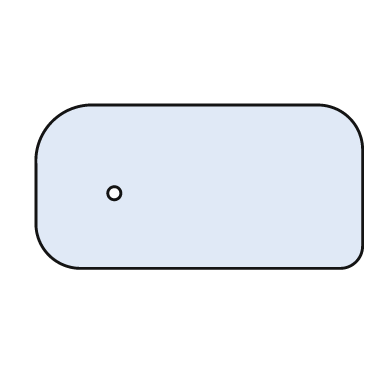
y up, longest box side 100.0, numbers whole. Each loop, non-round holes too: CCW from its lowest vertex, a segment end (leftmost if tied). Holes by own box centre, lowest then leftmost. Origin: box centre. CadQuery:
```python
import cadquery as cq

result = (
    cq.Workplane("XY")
    .moveTo(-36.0, -25.0)
    .lineTo(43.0, -25.0)
    .threePointArc((48.0, -23.0), (50.0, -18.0))
    .lineTo(50.0, 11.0)
    .threePointArc((46.0, 21.0), (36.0, 25.0))
    .lineTo(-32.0, 25.0)
    .threePointArc((-45.0, 20.0), (-50.0, 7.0))
    .lineTo(-50.0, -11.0)
    .threePointArc((-46.0, -21.0), (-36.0, -25.0))
    .close()
    .moveTo(-26.0, -2.0)
    .circle(2.0)
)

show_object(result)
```